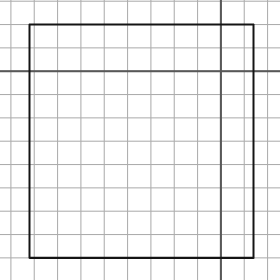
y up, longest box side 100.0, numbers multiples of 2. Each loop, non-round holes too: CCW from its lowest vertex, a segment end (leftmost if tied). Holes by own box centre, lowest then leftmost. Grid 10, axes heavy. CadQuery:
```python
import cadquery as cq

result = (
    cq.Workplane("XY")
    .moveTo(-82.0, -80.0)
    .lineTo(14.0, -80.0)
    .lineTo(14.0, 20.0)
    .lineTo(-82.0, 20.0)
    .close()
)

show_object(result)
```